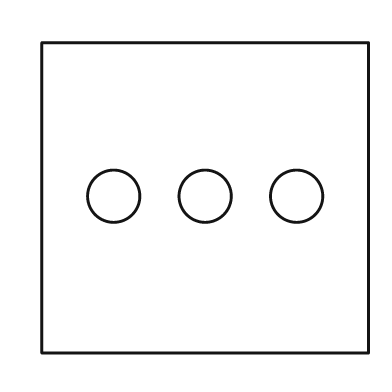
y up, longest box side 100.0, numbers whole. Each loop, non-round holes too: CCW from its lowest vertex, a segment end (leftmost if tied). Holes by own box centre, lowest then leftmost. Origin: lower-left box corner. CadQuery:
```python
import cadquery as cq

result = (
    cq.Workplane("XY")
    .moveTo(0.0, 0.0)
    .lineTo(100.0, 0.0)
    .lineTo(100.0, 95.0)
    .lineTo(0.0, 95.0)
    .close()
    .moveTo(22.0, 48.0)
    .circle(8.0)
    .moveTo(50.0, 48.0)
    .circle(8.0)
    .moveTo(78.0, 48.0)
    .circle(8.0)
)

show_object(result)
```